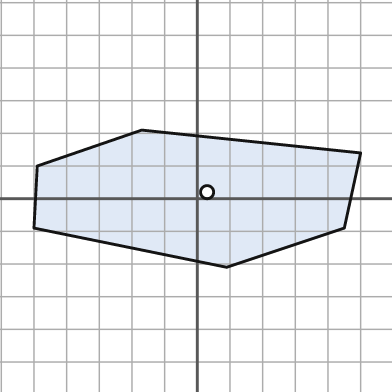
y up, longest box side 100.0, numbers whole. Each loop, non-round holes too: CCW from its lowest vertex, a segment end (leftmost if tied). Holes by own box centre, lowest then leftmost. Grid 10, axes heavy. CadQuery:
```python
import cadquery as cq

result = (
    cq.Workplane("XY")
    .moveTo(9.0, -21.0)
    .lineTo(45.0, -9.0)
    .lineTo(50.0, 14.0)
    .lineTo(-17.0, 21.0)
    .lineTo(-49.0, 10.0)
    .lineTo(-50.0, -9.0)
    .close()
    .moveTo(3.0, 2.0)
    .circle(2.0)
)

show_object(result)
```